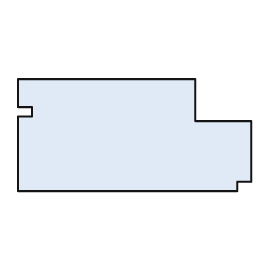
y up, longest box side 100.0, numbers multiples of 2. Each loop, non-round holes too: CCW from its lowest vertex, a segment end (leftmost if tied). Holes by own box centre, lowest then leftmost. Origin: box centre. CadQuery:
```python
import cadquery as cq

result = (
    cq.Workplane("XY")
    .moveTo(-50.0, -24.0)
    .lineTo(44.0, -24.0)
    .lineTo(44.0, -20.0)
    .lineTo(50.0, -20.0)
    .lineTo(50.0, 6.0)
    .lineTo(26.0, 6.0)
    .lineTo(26.0, 24.0)
    .lineTo(-50.0, 24.0)
    .lineTo(-50.0, 12.0)
    .lineTo(-44.0, 12.0)
    .lineTo(-44.0, 8.0)
    .lineTo(-50.0, 8.0)
    .close()
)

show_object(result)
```